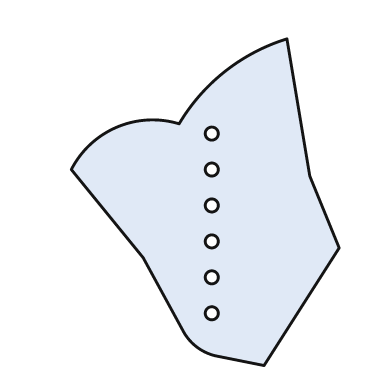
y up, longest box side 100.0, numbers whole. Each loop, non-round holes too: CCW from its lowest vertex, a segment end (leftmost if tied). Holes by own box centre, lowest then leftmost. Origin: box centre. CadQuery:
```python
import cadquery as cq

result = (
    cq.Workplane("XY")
    .moveTo(18.0, -50.0)
    .lineTo(41.0, -14.0)
    .lineTo(32.0, 8.0)
    .lineTo(25.0, 50.0)
    .threePointArc((6.0, 40.0), (-8.0, 24.0))
    .threePointArc((-27.0, 23.0), (-41.0, 10.0))
    .lineTo(-19.0, -17.0)
    .lineTo(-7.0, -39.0)
    .threePointArc((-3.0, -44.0), (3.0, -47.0))
    .close()
    .moveTo(2.0, -34.0)
    .circle(2.0)
    .moveTo(2.0, -23.0)
    .circle(2.0)
    .moveTo(2.0, -12.0)
    .circle(2.0)
    .moveTo(2.0, -1.0)
    .circle(2.0)
    .moveTo(2.0, 10.0)
    .circle(2.0)
    .moveTo(2.0, 21.0)
    .circle(2.0)
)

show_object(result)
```